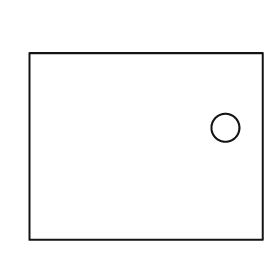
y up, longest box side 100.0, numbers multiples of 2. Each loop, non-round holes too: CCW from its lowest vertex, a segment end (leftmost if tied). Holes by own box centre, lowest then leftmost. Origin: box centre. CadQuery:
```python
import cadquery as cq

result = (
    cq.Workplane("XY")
    .moveTo(-50.0, -40.0)
    .lineTo(50.0, -40.0)
    .lineTo(50.0, 40.0)
    .lineTo(-50.0, 40.0)
    .close()
    .moveTo(34.0, 8.0)
    .circle(6.0)
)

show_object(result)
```